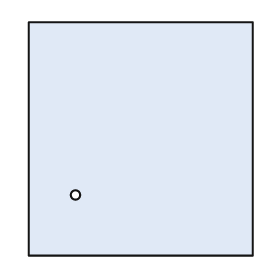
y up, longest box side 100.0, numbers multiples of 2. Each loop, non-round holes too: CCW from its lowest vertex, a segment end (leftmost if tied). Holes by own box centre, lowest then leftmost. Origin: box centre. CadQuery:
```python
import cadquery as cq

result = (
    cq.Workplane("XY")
    .moveTo(-48.0, -50.0)
    .lineTo(48.0, -50.0)
    .lineTo(48.0, 50.0)
    .lineTo(-48.0, 50.0)
    .close()
    .moveTo(-28.0, -24.0)
    .circle(2.0)
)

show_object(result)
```